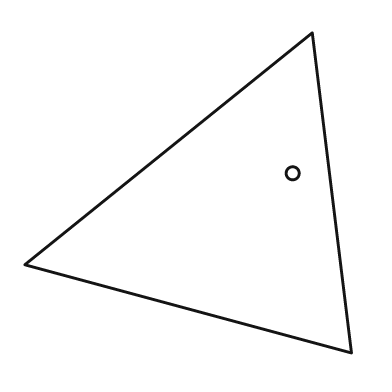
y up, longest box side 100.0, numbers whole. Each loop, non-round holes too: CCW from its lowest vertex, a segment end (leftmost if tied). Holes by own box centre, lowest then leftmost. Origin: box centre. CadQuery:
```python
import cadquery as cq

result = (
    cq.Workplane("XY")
    .moveTo(50.0, -49.0)
    .lineTo(38.0, 49.0)
    .lineTo(-50.0, -22.0)
    .close()
    .moveTo(32.0, 6.0)
    .circle(2.0)
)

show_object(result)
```